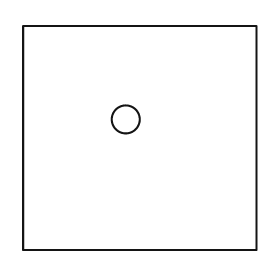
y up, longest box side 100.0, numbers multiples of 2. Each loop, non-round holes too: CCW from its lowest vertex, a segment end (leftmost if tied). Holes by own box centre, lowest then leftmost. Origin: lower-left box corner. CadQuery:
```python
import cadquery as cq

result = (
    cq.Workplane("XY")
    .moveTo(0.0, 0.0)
    .lineTo(100.0, 0.0)
    .lineTo(100.0, 96.0)
    .lineTo(0.0, 96.0)
    .close()
    .moveTo(44.0, 56.0)
    .circle(6.0)
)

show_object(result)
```